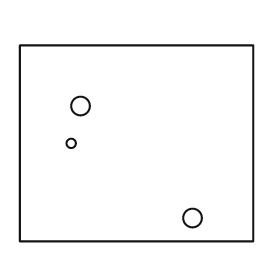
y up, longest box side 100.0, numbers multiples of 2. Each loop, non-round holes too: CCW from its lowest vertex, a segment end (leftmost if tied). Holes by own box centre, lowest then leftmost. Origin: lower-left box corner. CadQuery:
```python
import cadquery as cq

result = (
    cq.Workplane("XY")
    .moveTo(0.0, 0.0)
    .lineTo(100.0, 0.0)
    .lineTo(100.0, 84.0)
    .lineTo(0.0, 84.0)
    .close()
    .moveTo(74.0, 10.0)
    .circle(4.0)
    .moveTo(22.0, 42.0)
    .circle(2.0)
    .moveTo(26.0, 58.0)
    .circle(4.0)
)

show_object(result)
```